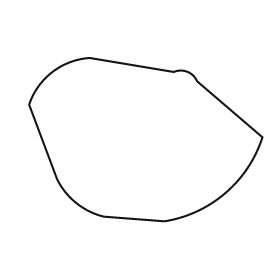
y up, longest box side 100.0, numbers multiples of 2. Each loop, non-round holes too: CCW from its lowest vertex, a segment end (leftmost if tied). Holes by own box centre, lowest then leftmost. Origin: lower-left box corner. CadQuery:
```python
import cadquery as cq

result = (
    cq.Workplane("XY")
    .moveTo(58.0, 0.0)
    .threePointArc((84.0, 12.0), (100.0, 36.0))
    .lineTo(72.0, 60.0)
    .threePointArc((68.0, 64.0), (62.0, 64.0))
    .lineTo(26.0, 70.0)
    .threePointArc((10.0, 64.0), (0.0, 50.0))
    .lineTo(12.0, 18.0)
    .threePointArc((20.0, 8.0), (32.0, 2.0))
    .close()
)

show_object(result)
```